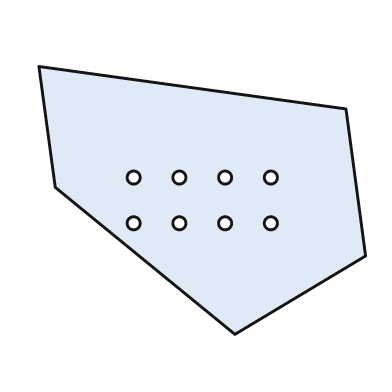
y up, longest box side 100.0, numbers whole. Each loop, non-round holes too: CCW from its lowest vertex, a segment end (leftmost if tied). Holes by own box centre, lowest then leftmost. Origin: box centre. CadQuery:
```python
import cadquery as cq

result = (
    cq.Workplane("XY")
    .moveTo(10.0, -41.0)
    .lineTo(50.0, -17.0)
    .lineTo(44.0, 28.0)
    .lineTo(-50.0, 41.0)
    .lineTo(-45.0, 4.0)
    .close()
    .moveTo(-21.0, -7.0)
    .circle(2.0)
    .moveTo(-7.0, -7.0)
    .circle(2.0)
    .moveTo(7.0, -7.0)
    .circle(2.0)
    .moveTo(21.0, -7.0)
    .circle(2.0)
    .moveTo(-21.0, 7.0)
    .circle(2.0)
    .moveTo(-7.0, 7.0)
    .circle(2.0)
    .moveTo(7.0, 7.0)
    .circle(2.0)
    .moveTo(21.0, 7.0)
    .circle(2.0)
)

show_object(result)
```